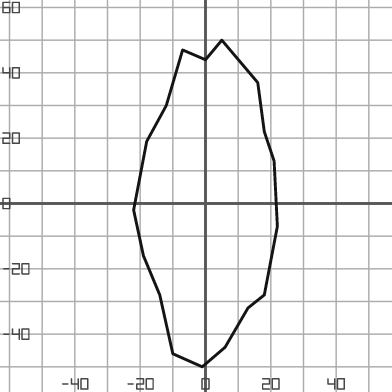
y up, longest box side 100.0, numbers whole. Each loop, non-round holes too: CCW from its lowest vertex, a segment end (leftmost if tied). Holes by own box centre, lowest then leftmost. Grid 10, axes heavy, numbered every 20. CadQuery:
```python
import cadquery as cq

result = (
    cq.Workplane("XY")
    .moveTo(-1.0, -50.0)
    .lineTo(6.0, -44.0)
    .lineTo(13.0, -32.0)
    .lineTo(18.0, -28.0)
    .lineTo(22.0, -7.0)
    .lineTo(21.0, 13.0)
    .lineTo(18.0, 22.0)
    .lineTo(16.0, 37.0)
    .lineTo(5.0, 50.0)
    .lineTo(0.0, 44.0)
    .lineTo(-7.0, 47.0)
    .lineTo(-12.0, 30.0)
    .lineTo(-18.0, 19.0)
    .lineTo(-22.0, -2.0)
    .lineTo(-19.0, -16.0)
    .lineTo(-14.0, -28.0)
    .lineTo(-10.0, -46.0)
    .close()
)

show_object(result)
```